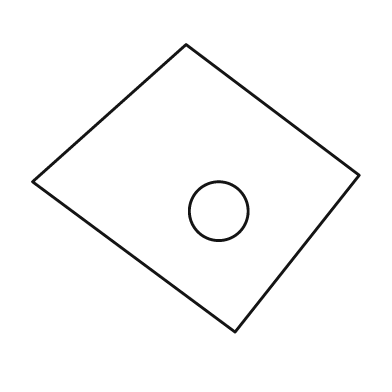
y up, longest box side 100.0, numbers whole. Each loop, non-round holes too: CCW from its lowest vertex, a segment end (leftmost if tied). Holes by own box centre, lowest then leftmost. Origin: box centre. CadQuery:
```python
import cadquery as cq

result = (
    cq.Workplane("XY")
    .moveTo(12.0, -44.0)
    .lineTo(50.0, 4.0)
    .lineTo(-3.0, 44.0)
    .lineTo(-50.0, 2.0)
    .close()
    .moveTo(7.0, -7.0)
    .circle(9.0)
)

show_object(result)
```